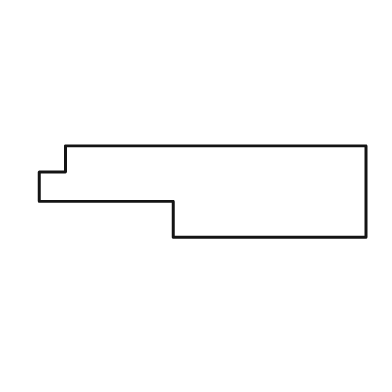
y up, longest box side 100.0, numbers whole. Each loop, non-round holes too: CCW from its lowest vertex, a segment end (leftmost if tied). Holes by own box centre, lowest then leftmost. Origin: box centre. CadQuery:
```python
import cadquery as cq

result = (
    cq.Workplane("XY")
    .moveTo(-9.0, -14.0)
    .lineTo(50.0, -14.0)
    .lineTo(50.0, 14.0)
    .lineTo(-42.0, 14.0)
    .lineTo(-42.0, 6.0)
    .lineTo(-50.0, 6.0)
    .lineTo(-50.0, -3.0)
    .lineTo(-9.0, -3.0)
    .close()
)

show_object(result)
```